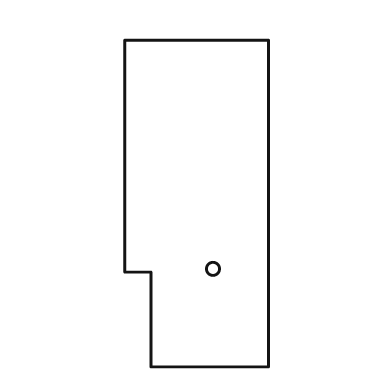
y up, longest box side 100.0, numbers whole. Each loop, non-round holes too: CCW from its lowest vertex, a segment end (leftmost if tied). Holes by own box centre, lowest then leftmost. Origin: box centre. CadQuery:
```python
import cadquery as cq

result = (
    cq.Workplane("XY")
    .moveTo(-14.0, -50.0)
    .lineTo(22.0, -50.0)
    .lineTo(22.0, 50.0)
    .lineTo(-22.0, 50.0)
    .lineTo(-22.0, -21.0)
    .lineTo(-14.0, -21.0)
    .close()
    .moveTo(5.0, -20.0)
    .circle(2.0)
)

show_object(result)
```